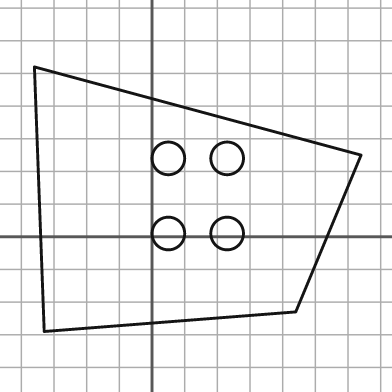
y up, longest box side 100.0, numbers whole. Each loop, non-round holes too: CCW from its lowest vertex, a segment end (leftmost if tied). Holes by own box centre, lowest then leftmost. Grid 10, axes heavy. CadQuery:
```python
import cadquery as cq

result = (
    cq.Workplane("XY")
    .moveTo(-33.0, -29.0)
    .lineTo(44.0, -23.0)
    .lineTo(64.0, 25.0)
    .lineTo(-36.0, 52.0)
    .close()
    .moveTo(5.0, 1.0)
    .circle(5.0)
    .moveTo(23.0, 1.0)
    .circle(5.0)
    .moveTo(5.0, 24.0)
    .circle(5.0)
    .moveTo(23.0, 24.0)
    .circle(5.0)
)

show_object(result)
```